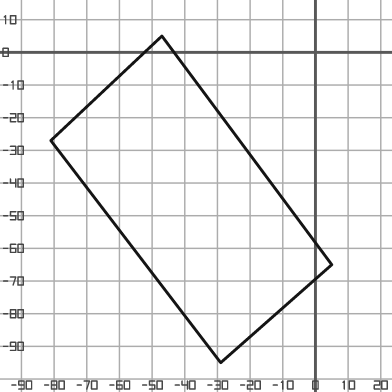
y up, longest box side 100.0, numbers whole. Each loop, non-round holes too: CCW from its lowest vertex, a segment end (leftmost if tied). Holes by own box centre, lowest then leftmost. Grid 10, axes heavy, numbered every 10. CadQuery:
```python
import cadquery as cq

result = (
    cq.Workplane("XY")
    .moveTo(-29.0, -95.0)
    .lineTo(5.0, -65.0)
    .lineTo(-47.0, 5.0)
    .lineTo(-81.0, -27.0)
    .close()
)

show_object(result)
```